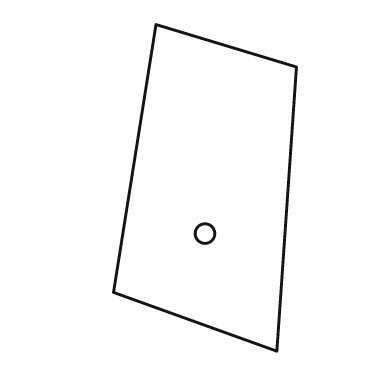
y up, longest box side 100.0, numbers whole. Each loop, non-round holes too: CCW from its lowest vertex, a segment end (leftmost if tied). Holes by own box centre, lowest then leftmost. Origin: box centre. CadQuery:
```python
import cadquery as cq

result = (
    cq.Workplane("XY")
    .moveTo(22.0, -50.0)
    .lineTo(28.0, 37.0)
    .lineTo(-15.0, 50.0)
    .lineTo(-28.0, -32.0)
    .close()
    .moveTo(0.0, -14.0)
    .circle(3.0)
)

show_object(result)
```